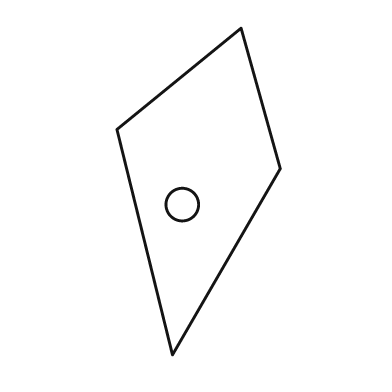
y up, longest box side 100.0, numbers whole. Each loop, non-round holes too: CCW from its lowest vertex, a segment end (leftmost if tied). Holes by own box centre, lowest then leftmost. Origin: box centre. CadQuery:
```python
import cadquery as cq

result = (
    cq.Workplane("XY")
    .moveTo(-8.0, -50.0)
    .lineTo(25.0, 7.0)
    .lineTo(13.0, 50.0)
    .lineTo(-25.0, 19.0)
    .close()
    .moveTo(-5.0, -4.0)
    .circle(5.0)
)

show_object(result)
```